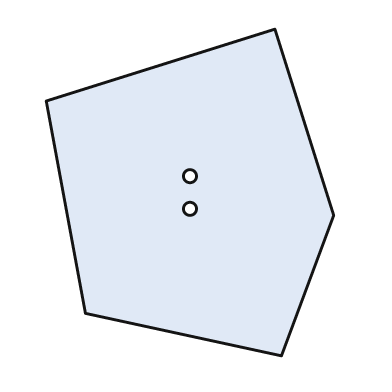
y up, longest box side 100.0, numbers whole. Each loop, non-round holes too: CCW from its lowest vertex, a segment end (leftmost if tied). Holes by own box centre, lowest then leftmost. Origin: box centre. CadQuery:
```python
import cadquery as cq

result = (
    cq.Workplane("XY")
    .moveTo(28.0, -50.0)
    .lineTo(44.0, -7.0)
    .lineTo(26.0, 50.0)
    .lineTo(-44.0, 28.0)
    .lineTo(-32.0, -37.0)
    .close()
    .moveTo(0.0, -5.0)
    .circle(2.0)
    .moveTo(0.0, 5.0)
    .circle(2.0)
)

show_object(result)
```